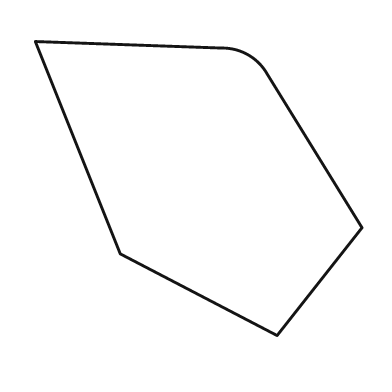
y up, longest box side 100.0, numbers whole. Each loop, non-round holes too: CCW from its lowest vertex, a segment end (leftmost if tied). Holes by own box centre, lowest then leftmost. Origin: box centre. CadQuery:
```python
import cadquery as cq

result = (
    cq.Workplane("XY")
    .moveTo(24.0, -45.0)
    .lineTo(50.0, -12.0)
    .lineTo(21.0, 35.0)
    .threePointArc((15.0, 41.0), (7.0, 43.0))
    .lineTo(-50.0, 45.0)
    .lineTo(-24.0, -20.0)
    .close()
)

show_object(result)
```